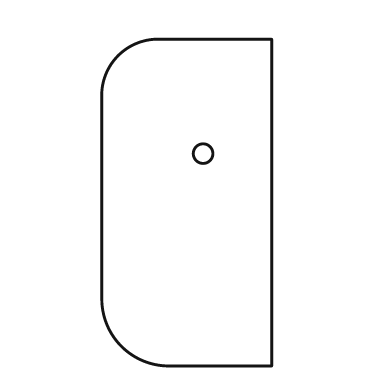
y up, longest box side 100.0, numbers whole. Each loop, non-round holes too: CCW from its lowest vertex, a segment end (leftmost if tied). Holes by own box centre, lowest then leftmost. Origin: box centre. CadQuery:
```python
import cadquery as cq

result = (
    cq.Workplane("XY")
    .moveTo(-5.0, -50.0)
    .lineTo(26.0, -50.0)
    .lineTo(26.0, 50.0)
    .lineTo(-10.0, 50.0)
    .threePointArc((-21.0, 45.0), (-26.0, 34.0))
    .lineTo(-26.0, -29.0)
    .threePointArc((-20.0, -44.0), (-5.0, -50.0))
    .close()
    .moveTo(5.0, 15.0)
    .circle(3.0)
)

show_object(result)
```